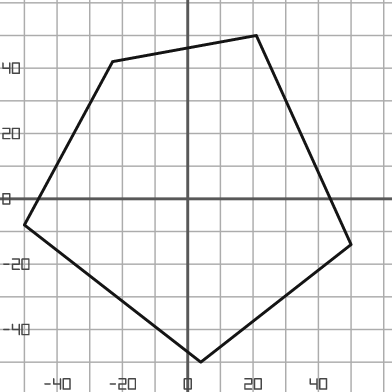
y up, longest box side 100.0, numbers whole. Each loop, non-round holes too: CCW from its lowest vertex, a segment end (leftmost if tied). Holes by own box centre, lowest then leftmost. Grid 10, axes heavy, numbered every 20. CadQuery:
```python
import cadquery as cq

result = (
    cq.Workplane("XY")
    .moveTo(4.0, -50.0)
    .lineTo(50.0, -14.0)
    .lineTo(21.0, 50.0)
    .lineTo(-23.0, 42.0)
    .lineTo(-50.0, -8.0)
    .close()
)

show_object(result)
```